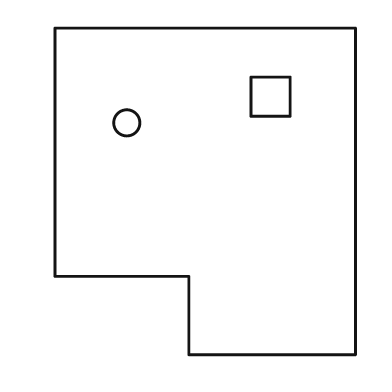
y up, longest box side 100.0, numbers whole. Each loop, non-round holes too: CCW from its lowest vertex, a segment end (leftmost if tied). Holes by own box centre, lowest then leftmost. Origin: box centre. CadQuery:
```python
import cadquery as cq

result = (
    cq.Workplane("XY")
    .moveTo(-5.0, -50.0)
    .lineTo(46.0, -50.0)
    .lineTo(46.0, 50.0)
    .lineTo(-46.0, 50.0)
    .lineTo(-46.0, -26.0)
    .lineTo(-5.0, -26.0)
    .close()
    .moveTo(-24.0, 21.0)
    .circle(4.0)
    .moveTo(14.0, 23.0)
    .lineTo(26.0, 23.0)
    .lineTo(26.0, 35.0)
    .lineTo(14.0, 35.0)
    .close()
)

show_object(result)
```